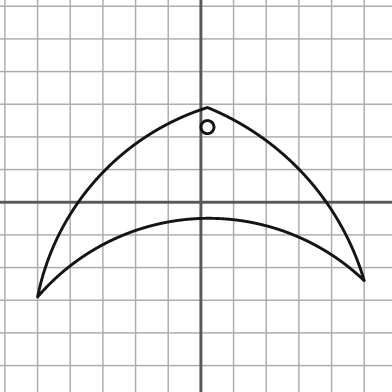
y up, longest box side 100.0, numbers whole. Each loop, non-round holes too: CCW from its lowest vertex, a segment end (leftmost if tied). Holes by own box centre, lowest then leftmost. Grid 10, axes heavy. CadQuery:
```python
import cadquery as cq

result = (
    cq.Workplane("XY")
    .moveTo(-50.0, -29.0)
    .threePointArc((-1.0, -5.0), (50.0, -24.0))
    .threePointArc((32.0, 8.0), (2.0, 29.0))
    .threePointArc((-32.0, 7.0), (-50.0, -29.0))
    .close()
    .moveTo(2.0, 23.0)
    .circle(2.0)
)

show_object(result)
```